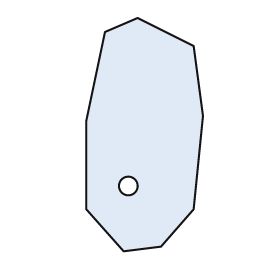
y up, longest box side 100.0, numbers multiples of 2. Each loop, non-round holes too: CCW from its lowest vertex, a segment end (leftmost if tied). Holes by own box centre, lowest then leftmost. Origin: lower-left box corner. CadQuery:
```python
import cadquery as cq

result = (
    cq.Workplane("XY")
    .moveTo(16.0, 0.0)
    .lineTo(32.0, 2.0)
    .lineTo(46.0, 18.0)
    .lineTo(50.0, 58.0)
    .lineTo(46.0, 88.0)
    .lineTo(22.0, 100.0)
    .lineTo(8.0, 94.0)
    .lineTo(0.0, 56.0)
    .lineTo(0.0, 18.0)
    .close()
    .moveTo(18.0, 28.0)
    .circle(4.0)
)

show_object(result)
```